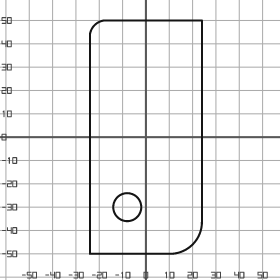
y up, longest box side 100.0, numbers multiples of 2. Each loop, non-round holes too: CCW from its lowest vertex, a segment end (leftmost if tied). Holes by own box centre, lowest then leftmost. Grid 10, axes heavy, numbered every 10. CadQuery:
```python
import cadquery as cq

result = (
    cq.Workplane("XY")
    .moveTo(-24.0, -50.0)
    .lineTo(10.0, -50.0)
    .threePointArc((20.0, -46.0), (24.0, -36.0))
    .lineTo(24.0, 50.0)
    .lineTo(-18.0, 50.0)
    .threePointArc((-22.0, 48.0), (-24.0, 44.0))
    .close()
    .moveTo(-8.0, -30.0)
    .circle(6.0)
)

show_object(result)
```